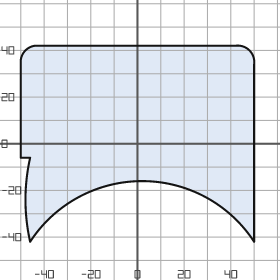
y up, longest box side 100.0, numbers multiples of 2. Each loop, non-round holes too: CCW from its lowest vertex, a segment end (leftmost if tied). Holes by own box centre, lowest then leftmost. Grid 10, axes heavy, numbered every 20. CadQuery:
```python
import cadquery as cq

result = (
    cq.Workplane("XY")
    .moveTo(-46.0, -42.0)
    .threePointArc((2.0, -16.0), (50.0, -42.0))
    .lineTo(50.0, 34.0)
    .threePointArc((48.0, 40.0), (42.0, 42.0))
    .lineTo(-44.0, 42.0)
    .threePointArc((-48.0, 40.0), (-50.0, 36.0))
    .lineTo(-50.0, -6.0)
    .lineTo(-46.0, -6.0)
    .threePointArc((-48.0, -24.0), (-46.0, -42.0))
    .close()
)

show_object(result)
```